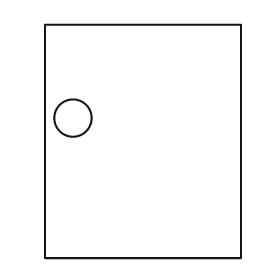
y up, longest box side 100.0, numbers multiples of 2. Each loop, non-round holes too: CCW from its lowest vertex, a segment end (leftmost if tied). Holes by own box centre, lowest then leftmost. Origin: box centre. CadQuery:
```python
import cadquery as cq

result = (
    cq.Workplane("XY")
    .moveTo(-42.0, -50.0)
    .lineTo(42.0, -50.0)
    .lineTo(42.0, 50.0)
    .lineTo(-42.0, 50.0)
    .close()
    .moveTo(-30.0, 10.0)
    .circle(8.0)
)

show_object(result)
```